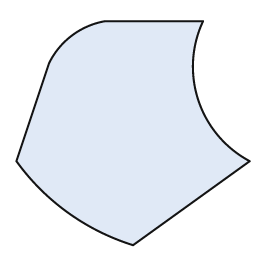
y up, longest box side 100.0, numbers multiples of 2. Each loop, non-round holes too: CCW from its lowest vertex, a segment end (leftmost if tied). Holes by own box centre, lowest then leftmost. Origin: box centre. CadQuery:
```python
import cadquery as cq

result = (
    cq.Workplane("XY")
    .moveTo(0.0, -48.0)
    .lineTo(50.0, -12.0)
    .threePointArc((28.0, 14.0), (30.0, 48.0))
    .lineTo(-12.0, 48.0)
    .threePointArc((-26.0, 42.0), (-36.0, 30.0))
    .lineTo(-50.0, -12.0)
    .threePointArc((-28.0, -34.0), (0.0, -48.0))
    .close()
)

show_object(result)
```